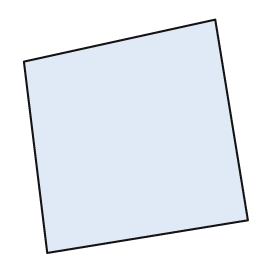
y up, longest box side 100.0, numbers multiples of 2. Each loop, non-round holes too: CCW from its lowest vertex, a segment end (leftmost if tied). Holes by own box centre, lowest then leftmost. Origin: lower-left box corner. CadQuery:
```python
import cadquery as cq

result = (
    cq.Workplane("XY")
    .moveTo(10.0, 0.0)
    .lineTo(96.0, 14.0)
    .lineTo(82.0, 100.0)
    .lineTo(0.0, 82.0)
    .close()
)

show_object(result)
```